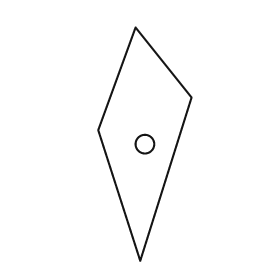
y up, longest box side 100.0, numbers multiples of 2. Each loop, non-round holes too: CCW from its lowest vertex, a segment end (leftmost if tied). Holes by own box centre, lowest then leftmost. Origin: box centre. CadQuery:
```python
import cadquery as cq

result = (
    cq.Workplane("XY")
    .moveTo(-2.0, -50.0)
    .lineTo(20.0, 20.0)
    .lineTo(-4.0, 50.0)
    .lineTo(-20.0, 6.0)
    .close()
    .moveTo(0.0, 0.0)
    .circle(4.0)
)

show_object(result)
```